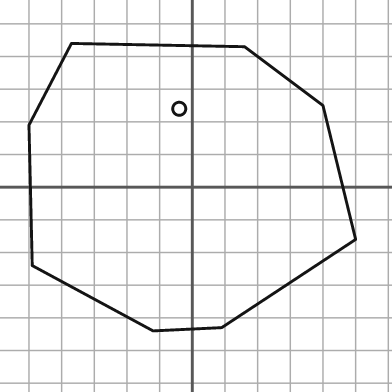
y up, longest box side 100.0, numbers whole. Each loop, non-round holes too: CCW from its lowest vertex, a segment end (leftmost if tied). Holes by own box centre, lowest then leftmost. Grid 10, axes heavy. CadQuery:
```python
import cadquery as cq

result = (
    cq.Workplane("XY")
    .moveTo(-12.0, -44.0)
    .lineTo(9.0, -43.0)
    .lineTo(50.0, -16.0)
    .lineTo(40.0, 25.0)
    .lineTo(16.0, 43.0)
    .lineTo(-37.0, 44.0)
    .lineTo(-50.0, 19.0)
    .lineTo(-49.0, -24.0)
    .close()
    .moveTo(-4.0, 24.0)
    .circle(2.0)
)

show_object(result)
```